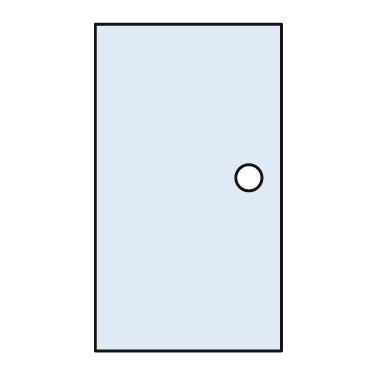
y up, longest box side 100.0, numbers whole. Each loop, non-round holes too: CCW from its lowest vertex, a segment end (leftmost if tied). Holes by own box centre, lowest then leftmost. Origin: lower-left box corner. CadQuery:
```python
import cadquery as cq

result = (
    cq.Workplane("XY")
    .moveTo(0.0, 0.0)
    .lineTo(57.0, 0.0)
    .lineTo(57.0, 100.0)
    .lineTo(0.0, 100.0)
    .close()
    .moveTo(47.0, 53.0)
    .circle(4.0)
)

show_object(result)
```